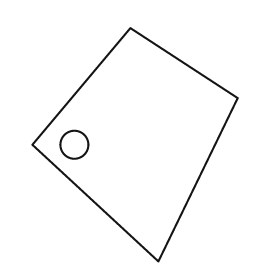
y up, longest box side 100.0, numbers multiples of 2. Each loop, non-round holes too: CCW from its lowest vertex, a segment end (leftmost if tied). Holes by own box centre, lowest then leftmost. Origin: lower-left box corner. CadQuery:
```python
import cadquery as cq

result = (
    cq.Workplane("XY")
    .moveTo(54.0, 0.0)
    .lineTo(88.0, 70.0)
    .lineTo(42.0, 100.0)
    .lineTo(0.0, 50.0)
    .close()
    .moveTo(18.0, 50.0)
    .circle(6.0)
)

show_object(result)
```